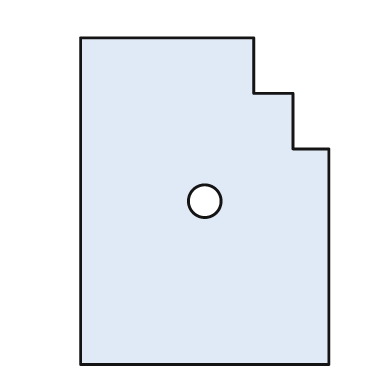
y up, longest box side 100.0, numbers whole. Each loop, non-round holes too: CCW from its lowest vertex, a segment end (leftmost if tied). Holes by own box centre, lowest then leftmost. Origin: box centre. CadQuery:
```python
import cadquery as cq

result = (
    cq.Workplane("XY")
    .moveTo(-38.0, -50.0)
    .lineTo(38.0, -50.0)
    .lineTo(38.0, 16.0)
    .lineTo(27.0, 16.0)
    .lineTo(27.0, 33.0)
    .lineTo(15.0, 33.0)
    .lineTo(15.0, 50.0)
    .lineTo(-38.0, 50.0)
    .close()
    .moveTo(0.0, 0.0)
    .circle(5.0)
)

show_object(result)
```